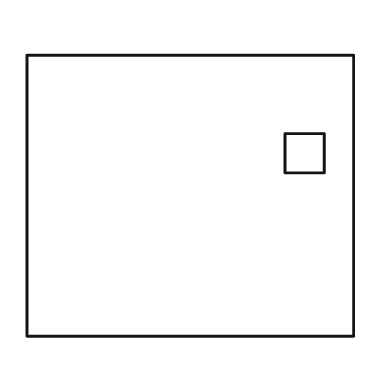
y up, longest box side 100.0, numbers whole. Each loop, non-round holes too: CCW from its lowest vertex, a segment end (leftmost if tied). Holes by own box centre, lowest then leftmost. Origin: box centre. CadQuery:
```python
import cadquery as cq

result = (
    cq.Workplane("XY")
    .moveTo(-50.0, -43.0)
    .lineTo(50.0, -43.0)
    .lineTo(50.0, 43.0)
    .lineTo(-50.0, 43.0)
    .close()
    .moveTo(29.0, 7.0)
    .lineTo(41.0, 7.0)
    .lineTo(41.0, 19.0)
    .lineTo(29.0, 19.0)
    .close()
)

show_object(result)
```